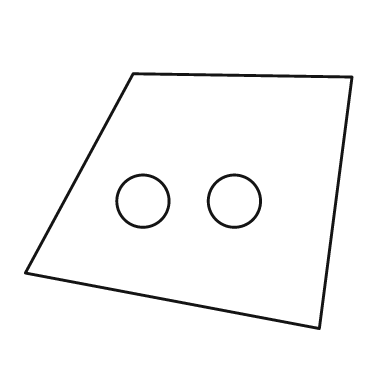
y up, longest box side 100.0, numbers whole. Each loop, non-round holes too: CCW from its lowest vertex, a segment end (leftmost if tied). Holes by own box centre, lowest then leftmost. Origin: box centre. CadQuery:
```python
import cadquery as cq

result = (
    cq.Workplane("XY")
    .moveTo(40.0, -39.0)
    .lineTo(50.0, 38.0)
    .lineTo(-17.0, 39.0)
    .lineTo(-50.0, -22.0)
    .close()
    .moveTo(-14.0, 0.0)
    .circle(8.0)
    .moveTo(14.0, 0.0)
    .circle(8.0)
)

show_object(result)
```